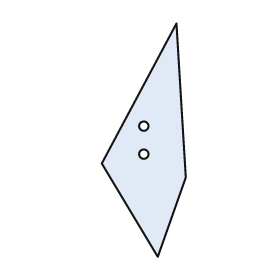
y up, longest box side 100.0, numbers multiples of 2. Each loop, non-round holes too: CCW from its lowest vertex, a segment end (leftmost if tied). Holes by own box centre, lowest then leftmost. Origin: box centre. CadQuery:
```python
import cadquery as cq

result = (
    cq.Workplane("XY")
    .moveTo(6.0, -50.0)
    .lineTo(18.0, -16.0)
    .lineTo(14.0, 50.0)
    .lineTo(-18.0, -10.0)
    .close()
    .moveTo(0.0, -6.0)
    .circle(2.0)
    .moveTo(0.0, 6.0)
    .circle(2.0)
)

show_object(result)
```